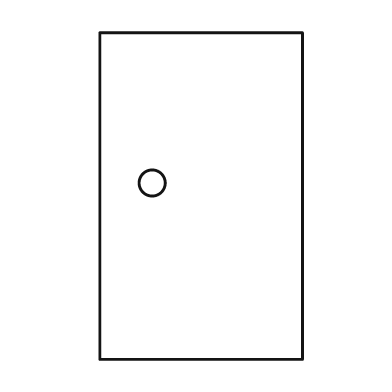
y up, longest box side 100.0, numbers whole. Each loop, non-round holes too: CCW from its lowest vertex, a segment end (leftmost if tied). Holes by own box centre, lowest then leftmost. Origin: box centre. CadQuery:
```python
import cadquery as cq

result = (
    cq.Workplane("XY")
    .moveTo(-31.0, -50.0)
    .lineTo(31.0, -50.0)
    .lineTo(31.0, 50.0)
    .lineTo(-31.0, 50.0)
    .close()
    .moveTo(-15.0, 4.0)
    .circle(4.0)
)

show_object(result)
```